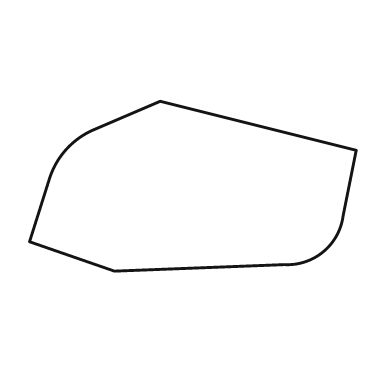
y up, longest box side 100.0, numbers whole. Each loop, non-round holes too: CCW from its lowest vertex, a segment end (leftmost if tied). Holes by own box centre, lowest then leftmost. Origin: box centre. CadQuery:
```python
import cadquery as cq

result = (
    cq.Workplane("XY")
    .moveTo(-24.0, -26.0)
    .lineTo(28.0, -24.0)
    .threePointArc((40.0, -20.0), (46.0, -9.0))
    .lineTo(50.0, 11.0)
    .lineTo(-10.0, 26.0)
    .lineTo(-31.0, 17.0)
    .threePointArc((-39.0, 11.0), (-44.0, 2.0))
    .lineTo(-50.0, -17.0)
    .close()
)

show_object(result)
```